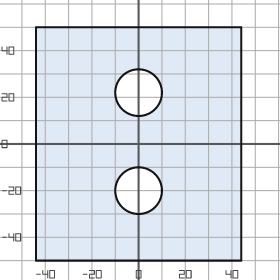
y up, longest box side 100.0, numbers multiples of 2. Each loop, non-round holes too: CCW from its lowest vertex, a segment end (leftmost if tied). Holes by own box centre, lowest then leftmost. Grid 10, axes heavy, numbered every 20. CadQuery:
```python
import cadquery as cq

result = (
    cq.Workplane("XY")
    .moveTo(-44.0, -50.0)
    .lineTo(44.0, -50.0)
    .lineTo(44.0, 50.0)
    .lineTo(-44.0, 50.0)
    .close()
    .moveTo(0.0, -20.0)
    .circle(10.0)
    .moveTo(0.0, 22.0)
    .circle(10.0)
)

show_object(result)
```